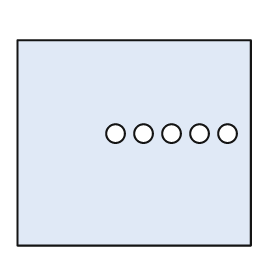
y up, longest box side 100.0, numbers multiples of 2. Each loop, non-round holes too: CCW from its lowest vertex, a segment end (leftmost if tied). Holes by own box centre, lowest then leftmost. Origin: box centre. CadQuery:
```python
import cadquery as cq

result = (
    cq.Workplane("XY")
    .moveTo(-50.0, -44.0)
    .lineTo(50.0, -44.0)
    .lineTo(50.0, 44.0)
    .lineTo(-50.0, 44.0)
    .close()
    .moveTo(-8.0, 4.0)
    .circle(4.0)
    .moveTo(4.0, 4.0)
    .circle(4.0)
    .moveTo(16.0, 4.0)
    .circle(4.0)
    .moveTo(28.0, 4.0)
    .circle(4.0)
    .moveTo(40.0, 4.0)
    .circle(4.0)
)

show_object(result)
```